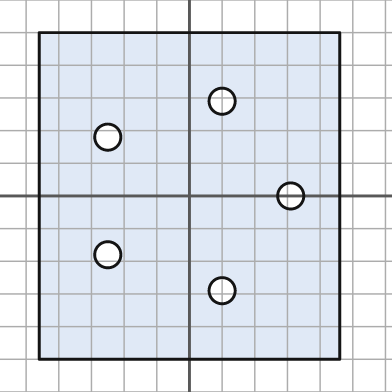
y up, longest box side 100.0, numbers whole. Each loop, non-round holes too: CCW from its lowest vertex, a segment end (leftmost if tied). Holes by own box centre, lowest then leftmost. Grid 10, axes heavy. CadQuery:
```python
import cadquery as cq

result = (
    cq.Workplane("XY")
    .moveTo(-46.0, -50.0)
    .lineTo(46.0, -50.0)
    .lineTo(46.0, 50.0)
    .lineTo(-46.0, 50.0)
    .close()
    .moveTo(10.0, -29.0)
    .circle(4.0)
    .moveTo(-25.0, -18.0)
    .circle(4.0)
    .moveTo(31.0, 0.0)
    .circle(4.0)
    .moveTo(-25.0, 18.0)
    .circle(4.0)
    .moveTo(10.0, 29.0)
    .circle(4.0)
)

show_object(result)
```